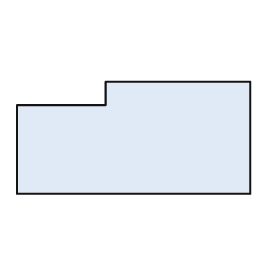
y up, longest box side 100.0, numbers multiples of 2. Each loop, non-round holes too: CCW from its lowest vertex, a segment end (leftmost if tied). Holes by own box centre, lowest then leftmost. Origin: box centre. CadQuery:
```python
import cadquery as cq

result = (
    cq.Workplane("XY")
    .moveTo(-50.0, -24.0)
    .lineTo(50.0, -24.0)
    .lineTo(50.0, 24.0)
    .lineTo(-12.0, 24.0)
    .lineTo(-12.0, 14.0)
    .lineTo(-50.0, 14.0)
    .close()
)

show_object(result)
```